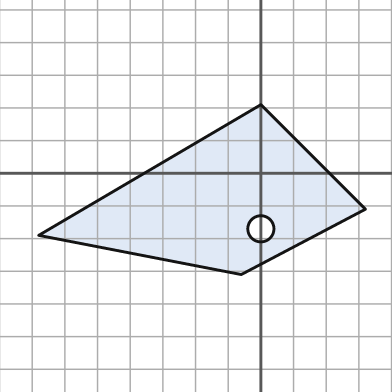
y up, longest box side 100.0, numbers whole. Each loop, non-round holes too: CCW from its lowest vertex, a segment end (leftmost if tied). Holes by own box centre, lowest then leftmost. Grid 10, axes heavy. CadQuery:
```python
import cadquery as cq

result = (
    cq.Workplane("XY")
    .moveTo(-6.0, -31.0)
    .lineTo(32.0, -11.0)
    .lineTo(0.0, 21.0)
    .lineTo(-68.0, -19.0)
    .close()
    .moveTo(0.0, -17.0)
    .circle(4.0)
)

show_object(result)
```